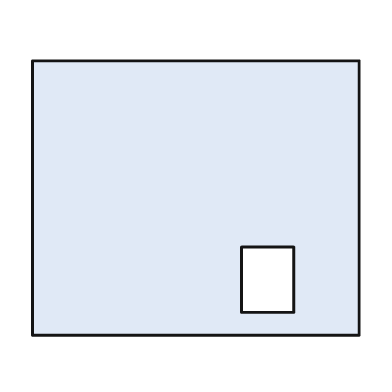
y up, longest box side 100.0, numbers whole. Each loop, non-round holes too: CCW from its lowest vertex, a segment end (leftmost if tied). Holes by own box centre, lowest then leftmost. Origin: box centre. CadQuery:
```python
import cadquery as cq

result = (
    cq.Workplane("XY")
    .moveTo(-50.0, -42.0)
    .lineTo(50.0, -42.0)
    .lineTo(50.0, 42.0)
    .lineTo(-50.0, 42.0)
    .close()
    .moveTo(14.0, -35.0)
    .lineTo(30.0, -35.0)
    .lineTo(30.0, -15.0)
    .lineTo(14.0, -15.0)
    .close()
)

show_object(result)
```